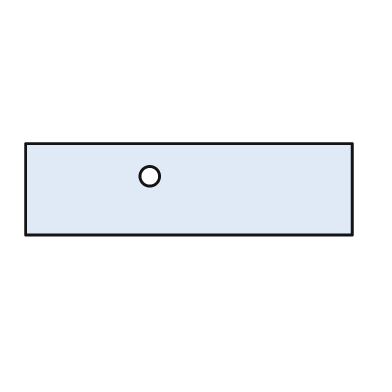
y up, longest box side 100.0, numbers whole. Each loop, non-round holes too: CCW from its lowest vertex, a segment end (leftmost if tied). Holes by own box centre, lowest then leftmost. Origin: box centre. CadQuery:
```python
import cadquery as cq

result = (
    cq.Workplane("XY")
    .moveTo(-50.0, -14.0)
    .lineTo(50.0, -14.0)
    .lineTo(50.0, 14.0)
    .lineTo(-50.0, 14.0)
    .close()
    .moveTo(-12.0, 4.0)
    .circle(3.0)
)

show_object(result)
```